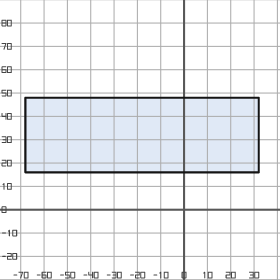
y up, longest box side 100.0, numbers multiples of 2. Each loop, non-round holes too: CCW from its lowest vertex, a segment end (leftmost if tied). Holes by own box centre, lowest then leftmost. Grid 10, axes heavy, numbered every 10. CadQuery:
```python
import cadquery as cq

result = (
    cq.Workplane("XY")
    .moveTo(-68.0, 16.0)
    .lineTo(32.0, 16.0)
    .lineTo(32.0, 48.0)
    .lineTo(-68.0, 48.0)
    .close()
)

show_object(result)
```